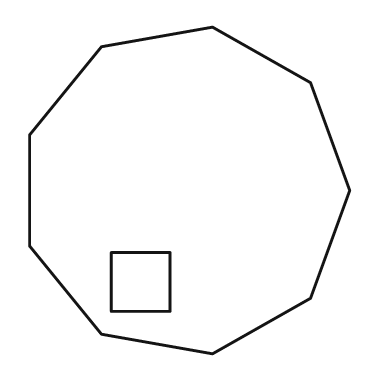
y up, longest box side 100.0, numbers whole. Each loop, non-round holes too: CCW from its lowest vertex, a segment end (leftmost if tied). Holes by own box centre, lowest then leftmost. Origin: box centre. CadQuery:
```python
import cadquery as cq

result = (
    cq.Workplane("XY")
    .moveTo(7.0, -50.0)
    .lineTo(37.0, -33.0)
    .lineTo(49.0, 0.0)
    .lineTo(37.0, 33.0)
    .lineTo(7.0, 50.0)
    .lineTo(-27.0, 44.0)
    .lineTo(-49.0, 17.0)
    .lineTo(-49.0, -17.0)
    .lineTo(-27.0, -44.0)
    .close()
    .moveTo(-24.0, -37.0)
    .lineTo(-6.0, -37.0)
    .lineTo(-6.0, -19.0)
    .lineTo(-24.0, -19.0)
    .close()
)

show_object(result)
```